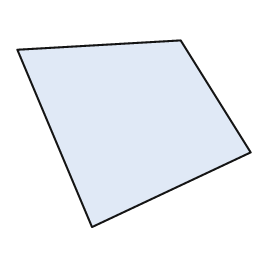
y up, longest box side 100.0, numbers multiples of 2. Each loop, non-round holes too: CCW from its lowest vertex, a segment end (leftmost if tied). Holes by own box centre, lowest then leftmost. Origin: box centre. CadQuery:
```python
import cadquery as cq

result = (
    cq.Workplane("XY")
    .moveTo(-18.0, -40.0)
    .lineTo(50.0, -8.0)
    .lineTo(20.0, 40.0)
    .lineTo(-50.0, 36.0)
    .close()
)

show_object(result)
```